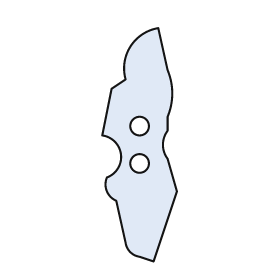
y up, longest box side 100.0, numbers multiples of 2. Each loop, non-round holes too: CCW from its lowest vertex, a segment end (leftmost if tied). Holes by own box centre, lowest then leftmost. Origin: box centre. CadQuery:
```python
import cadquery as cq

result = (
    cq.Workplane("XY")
    .moveTo(6.0, -50.0)
    .lineTo(16.0, -20.0)
    .lineTo(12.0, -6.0)
    .threePointArc((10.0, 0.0), (12.0, 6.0))
    .lineTo(12.0, 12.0)
    .threePointArc((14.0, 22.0), (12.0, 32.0))
    .lineTo(8.0, 50.0)
    .threePointArc((-4.0, 42.0), (-6.0, 28.0))
    .lineTo(-12.0, 24.0)
    .lineTo(-16.0, 4.0)
    .threePointArc((-8.0, -4.0), (-14.0, -14.0))
    .threePointArc((-14.0, -20.0), (-10.0, -24.0))
    .lineTo(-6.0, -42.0)
    .threePointArc((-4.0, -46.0), (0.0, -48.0))
    .close()
    .moveTo(0.0, -8.0)
    .circle(4.0)
    .moveTo(0.0, 8.0)
    .circle(4.0)
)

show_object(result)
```